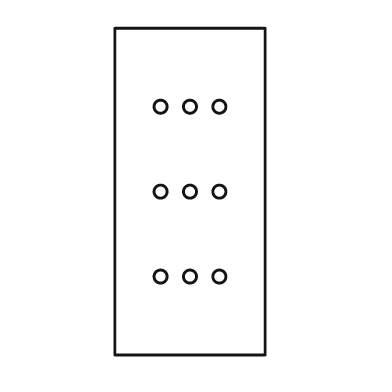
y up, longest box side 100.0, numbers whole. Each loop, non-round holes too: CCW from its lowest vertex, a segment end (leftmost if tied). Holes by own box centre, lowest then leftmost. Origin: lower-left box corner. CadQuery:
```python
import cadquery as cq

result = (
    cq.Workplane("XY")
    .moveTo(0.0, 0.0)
    .lineTo(46.0, 0.0)
    .lineTo(46.0, 100.0)
    .lineTo(0.0, 100.0)
    .close()
    .moveTo(14.0, 24.0)
    .circle(2.0)
    .moveTo(23.0, 24.0)
    .circle(2.0)
    .moveTo(32.0, 24.0)
    .circle(2.0)
    .moveTo(14.0, 50.0)
    .circle(2.0)
    .moveTo(23.0, 50.0)
    .circle(2.0)
    .moveTo(32.0, 50.0)
    .circle(2.0)
    .moveTo(14.0, 76.0)
    .circle(2.0)
    .moveTo(23.0, 76.0)
    .circle(2.0)
    .moveTo(32.0, 76.0)
    .circle(2.0)
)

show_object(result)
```